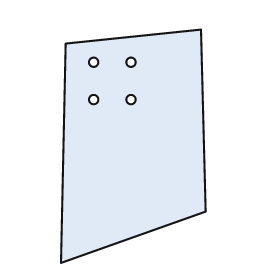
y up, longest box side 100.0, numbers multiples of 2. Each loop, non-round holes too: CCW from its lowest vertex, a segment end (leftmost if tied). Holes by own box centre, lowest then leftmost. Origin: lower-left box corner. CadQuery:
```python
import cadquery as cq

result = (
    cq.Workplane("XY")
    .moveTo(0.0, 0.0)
    .lineTo(62.0, 22.0)
    .lineTo(60.0, 100.0)
    .lineTo(2.0, 94.0)
    .close()
    .moveTo(14.0, 70.0)
    .circle(2.0)
    .moveTo(30.0, 70.0)
    .circle(2.0)
    .moveTo(14.0, 86.0)
    .circle(2.0)
    .moveTo(30.0, 86.0)
    .circle(2.0)
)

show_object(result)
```